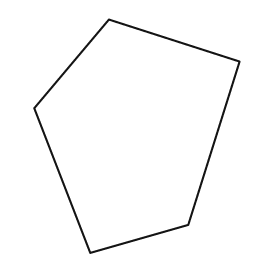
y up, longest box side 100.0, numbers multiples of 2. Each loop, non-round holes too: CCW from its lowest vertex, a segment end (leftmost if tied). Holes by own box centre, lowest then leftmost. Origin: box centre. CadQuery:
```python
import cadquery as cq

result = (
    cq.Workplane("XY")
    .moveTo(-20.0, -50.0)
    .lineTo(22.0, -38.0)
    .lineTo(44.0, 32.0)
    .lineTo(-12.0, 50.0)
    .lineTo(-44.0, 12.0)
    .close()
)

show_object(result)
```